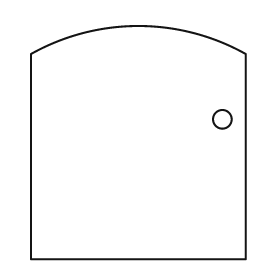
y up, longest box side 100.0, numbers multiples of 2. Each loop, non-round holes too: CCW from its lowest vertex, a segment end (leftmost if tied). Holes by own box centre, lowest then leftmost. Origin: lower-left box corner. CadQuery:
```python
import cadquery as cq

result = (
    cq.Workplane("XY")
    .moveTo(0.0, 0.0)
    .lineTo(92.0, 0.0)
    .lineTo(92.0, 88.0)
    .threePointArc((46.0, 100.0), (0.0, 88.0))
    .close()
    .moveTo(82.0, 60.0)
    .circle(4.0)
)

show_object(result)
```